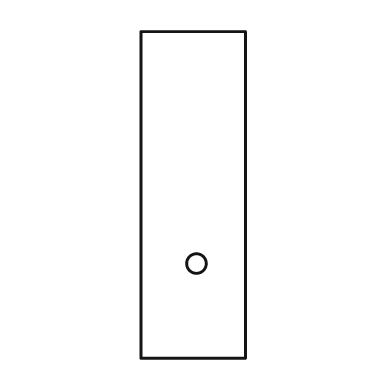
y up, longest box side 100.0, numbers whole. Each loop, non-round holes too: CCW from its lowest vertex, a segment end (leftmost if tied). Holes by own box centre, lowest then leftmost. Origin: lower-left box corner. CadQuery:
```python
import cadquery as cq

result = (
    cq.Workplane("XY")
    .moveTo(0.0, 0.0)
    .lineTo(32.0, 0.0)
    .lineTo(32.0, 100.0)
    .lineTo(0.0, 100.0)
    .close()
    .moveTo(17.0, 29.0)
    .circle(3.0)
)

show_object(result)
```